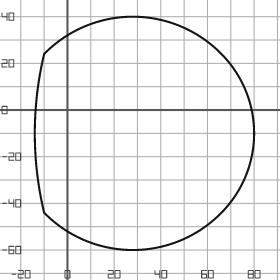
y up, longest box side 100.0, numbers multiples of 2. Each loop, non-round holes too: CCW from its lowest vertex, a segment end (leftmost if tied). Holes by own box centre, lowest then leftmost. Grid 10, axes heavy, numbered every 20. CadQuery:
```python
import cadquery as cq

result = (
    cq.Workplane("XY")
    .moveTo(-10.0, -44.0)
    .threePointArc((28.0, -60.0), (66.0, -44.0))
    .threePointArc((80.0, -10.0), (66.0, 24.0))
    .threePointArc((28.0, 40.0), (-10.0, 24.0))
    .threePointArc((-14.0, -10.0), (-10.0, -44.0))
    .close()
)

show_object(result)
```